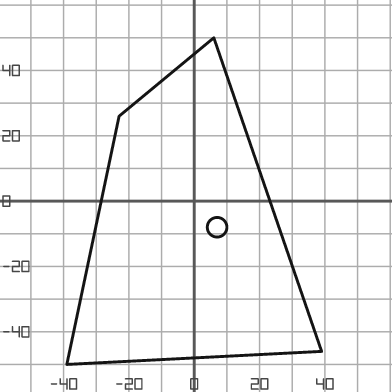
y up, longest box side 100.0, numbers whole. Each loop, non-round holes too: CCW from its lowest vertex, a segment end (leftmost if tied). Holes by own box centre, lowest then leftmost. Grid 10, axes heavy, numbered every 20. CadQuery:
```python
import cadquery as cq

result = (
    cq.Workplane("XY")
    .moveTo(-39.0, -50.0)
    .lineTo(39.0, -46.0)
    .lineTo(6.0, 50.0)
    .lineTo(-23.0, 26.0)
    .close()
    .moveTo(7.0, -8.0)
    .circle(3.0)
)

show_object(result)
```